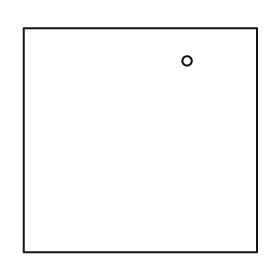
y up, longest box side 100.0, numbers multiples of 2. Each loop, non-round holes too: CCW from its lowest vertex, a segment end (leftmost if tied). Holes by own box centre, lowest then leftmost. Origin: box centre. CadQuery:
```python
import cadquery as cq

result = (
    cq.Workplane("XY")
    .moveTo(-50.0, -48.0)
    .lineTo(50.0, -48.0)
    .lineTo(50.0, 48.0)
    .lineTo(-50.0, 48.0)
    .close()
    .moveTo(20.0, 34.0)
    .circle(2.0)
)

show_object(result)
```